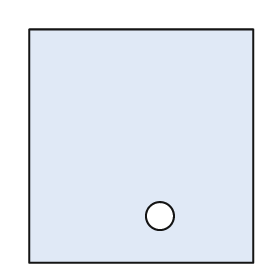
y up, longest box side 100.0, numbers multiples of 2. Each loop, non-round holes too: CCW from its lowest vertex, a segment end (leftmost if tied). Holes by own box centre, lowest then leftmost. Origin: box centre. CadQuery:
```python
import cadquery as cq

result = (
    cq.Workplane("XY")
    .moveTo(-48.0, -50.0)
    .lineTo(48.0, -50.0)
    .lineTo(48.0, 50.0)
    .lineTo(-48.0, 50.0)
    .close()
    .moveTo(8.0, -30.0)
    .circle(6.0)
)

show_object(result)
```